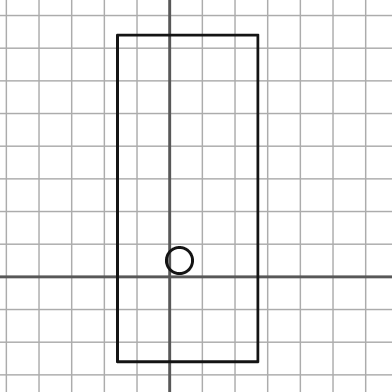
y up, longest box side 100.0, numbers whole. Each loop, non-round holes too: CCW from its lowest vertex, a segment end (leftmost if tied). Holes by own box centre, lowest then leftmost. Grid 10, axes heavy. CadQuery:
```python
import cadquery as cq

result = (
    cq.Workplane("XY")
    .moveTo(-16.0, -26.0)
    .lineTo(27.0, -26.0)
    .lineTo(27.0, 74.0)
    .lineTo(-16.0, 74.0)
    .close()
    .moveTo(3.0, 5.0)
    .circle(4.0)
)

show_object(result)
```